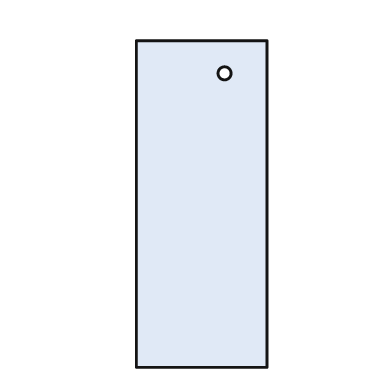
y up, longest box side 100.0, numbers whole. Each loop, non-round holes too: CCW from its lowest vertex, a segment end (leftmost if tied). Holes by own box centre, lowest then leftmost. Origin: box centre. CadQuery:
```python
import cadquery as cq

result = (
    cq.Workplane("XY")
    .moveTo(-20.0, -50.0)
    .lineTo(20.0, -50.0)
    .lineTo(20.0, 50.0)
    .lineTo(-20.0, 50.0)
    .close()
    .moveTo(7.0, 40.0)
    .circle(2.0)
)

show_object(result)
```